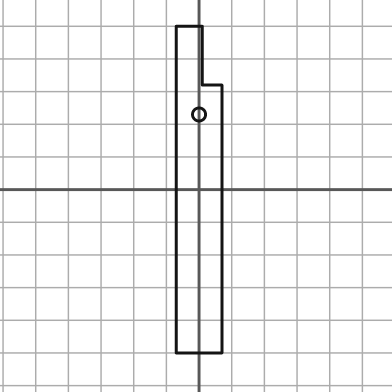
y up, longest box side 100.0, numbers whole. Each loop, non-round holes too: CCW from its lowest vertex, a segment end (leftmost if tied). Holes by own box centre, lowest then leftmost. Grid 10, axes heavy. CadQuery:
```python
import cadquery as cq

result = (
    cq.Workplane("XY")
    .moveTo(-7.0, -50.0)
    .lineTo(7.0, -50.0)
    .lineTo(7.0, 32.0)
    .lineTo(1.0, 32.0)
    .lineTo(1.0, 50.0)
    .lineTo(-7.0, 50.0)
    .close()
    .moveTo(0.0, 23.0)
    .circle(2.0)
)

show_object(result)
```